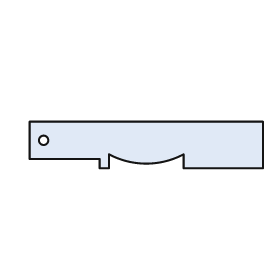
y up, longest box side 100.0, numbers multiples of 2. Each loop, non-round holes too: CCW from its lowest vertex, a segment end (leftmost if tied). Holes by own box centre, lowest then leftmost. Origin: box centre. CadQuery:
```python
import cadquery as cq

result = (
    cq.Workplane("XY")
    .moveTo(-20.0, -10.0)
    .lineTo(-16.0, -10.0)
    .lineTo(-16.0, -4.0)
    .threePointArc((0.0, -8.0), (16.0, -4.0))
    .lineTo(16.0, -10.0)
    .lineTo(50.0, -10.0)
    .lineTo(50.0, 10.0)
    .lineTo(-50.0, 10.0)
    .lineTo(-50.0, -6.0)
    .lineTo(-20.0, -6.0)
    .close()
    .moveTo(-44.0, 2.0)
    .circle(2.0)
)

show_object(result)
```